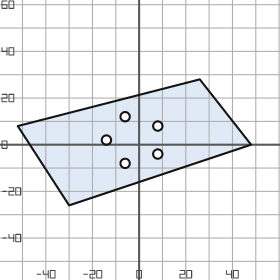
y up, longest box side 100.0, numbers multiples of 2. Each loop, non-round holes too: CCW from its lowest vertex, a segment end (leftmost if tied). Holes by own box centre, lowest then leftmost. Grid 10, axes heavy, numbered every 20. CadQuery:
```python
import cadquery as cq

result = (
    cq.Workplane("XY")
    .moveTo(-30.0, -26.0)
    .lineTo(48.0, 0.0)
    .lineTo(26.0, 28.0)
    .lineTo(-52.0, 8.0)
    .close()
    .moveTo(-6.0, -8.0)
    .circle(2.0)
    .moveTo(8.0, -4.0)
    .circle(2.0)
    .moveTo(-14.0, 2.0)
    .circle(2.0)
    .moveTo(8.0, 8.0)
    .circle(2.0)
    .moveTo(-6.0, 12.0)
    .circle(2.0)
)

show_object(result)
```